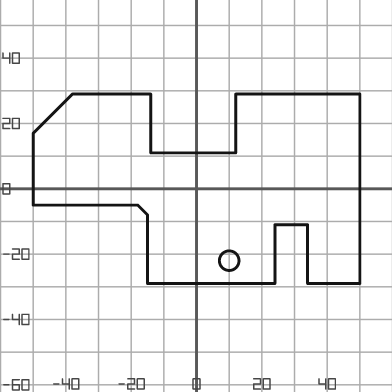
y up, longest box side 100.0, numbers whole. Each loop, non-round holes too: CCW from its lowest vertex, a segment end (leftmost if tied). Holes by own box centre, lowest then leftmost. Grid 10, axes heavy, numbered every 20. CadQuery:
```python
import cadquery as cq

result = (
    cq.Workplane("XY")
    .moveTo(-15.0, -29.0)
    .lineTo(24.0, -29.0)
    .lineTo(24.0, -11.0)
    .lineTo(34.0, -11.0)
    .lineTo(34.0, -29.0)
    .lineTo(50.0, -29.0)
    .lineTo(50.0, 29.0)
    .lineTo(12.0, 29.0)
    .lineTo(12.0, 11.0)
    .lineTo(-14.0, 11.0)
    .lineTo(-14.0, 29.0)
    .lineTo(-38.0, 29.0)
    .lineTo(-50.0, 17.0)
    .lineTo(-50.0, -5.0)
    .lineTo(-18.0, -5.0)
    .lineTo(-15.0, -8.0)
    .close()
    .moveTo(10.0, -22.0)
    .circle(3.0)
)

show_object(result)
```